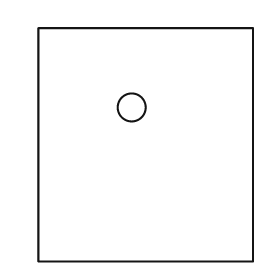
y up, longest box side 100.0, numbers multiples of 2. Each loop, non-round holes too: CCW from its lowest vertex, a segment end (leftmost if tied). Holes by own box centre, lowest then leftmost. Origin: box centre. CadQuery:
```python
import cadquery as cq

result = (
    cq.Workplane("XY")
    .moveTo(-46.0, -50.0)
    .lineTo(46.0, -50.0)
    .lineTo(46.0, 50.0)
    .lineTo(-46.0, 50.0)
    .close()
    .moveTo(-6.0, 16.0)
    .circle(6.0)
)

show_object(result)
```